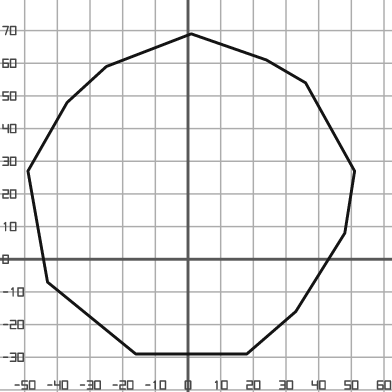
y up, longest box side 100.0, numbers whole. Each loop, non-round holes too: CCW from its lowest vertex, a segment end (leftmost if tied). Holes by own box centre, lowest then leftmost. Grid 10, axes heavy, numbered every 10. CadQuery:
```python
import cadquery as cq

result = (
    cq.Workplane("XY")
    .moveTo(-16.0, -29.0)
    .lineTo(18.0, -29.0)
    .lineTo(33.0, -16.0)
    .lineTo(48.0, 8.0)
    .lineTo(51.0, 27.0)
    .lineTo(36.0, 54.0)
    .lineTo(24.0, 61.0)
    .lineTo(1.0, 69.0)
    .lineTo(-25.0, 59.0)
    .lineTo(-37.0, 48.0)
    .lineTo(-49.0, 27.0)
    .lineTo(-43.0, -7.0)
    .close()
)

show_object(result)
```